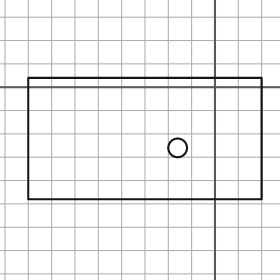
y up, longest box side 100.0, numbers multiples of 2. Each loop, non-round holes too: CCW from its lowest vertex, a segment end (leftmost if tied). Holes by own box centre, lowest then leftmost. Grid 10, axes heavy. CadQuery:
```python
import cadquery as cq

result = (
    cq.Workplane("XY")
    .moveTo(-80.0, -48.0)
    .lineTo(20.0, -48.0)
    .lineTo(20.0, 4.0)
    .lineTo(-80.0, 4.0)
    .close()
    .moveTo(-16.0, -26.0)
    .circle(4.0)
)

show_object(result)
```